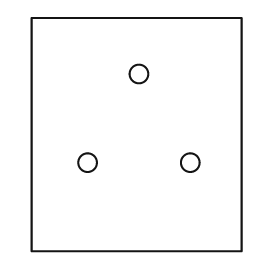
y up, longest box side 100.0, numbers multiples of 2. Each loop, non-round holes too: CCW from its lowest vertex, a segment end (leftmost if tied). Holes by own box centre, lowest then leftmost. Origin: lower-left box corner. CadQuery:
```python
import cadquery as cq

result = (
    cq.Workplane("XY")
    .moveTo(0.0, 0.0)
    .lineTo(90.0, 0.0)
    .lineTo(90.0, 100.0)
    .lineTo(0.0, 100.0)
    .close()
    .moveTo(24.0, 38.0)
    .circle(4.0)
    .moveTo(68.0, 38.0)
    .circle(4.0)
    .moveTo(46.0, 76.0)
    .circle(4.0)
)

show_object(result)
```